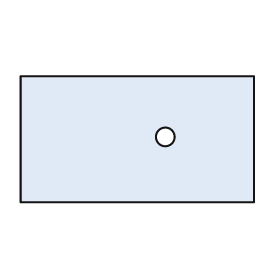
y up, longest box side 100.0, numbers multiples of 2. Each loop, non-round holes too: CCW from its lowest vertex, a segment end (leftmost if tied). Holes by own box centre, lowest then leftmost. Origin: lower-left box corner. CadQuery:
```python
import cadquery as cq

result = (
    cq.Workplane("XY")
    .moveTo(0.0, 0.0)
    .lineTo(100.0, 0.0)
    .lineTo(100.0, 54.0)
    .lineTo(0.0, 54.0)
    .close()
    .moveTo(62.0, 28.0)
    .circle(4.0)
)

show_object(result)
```